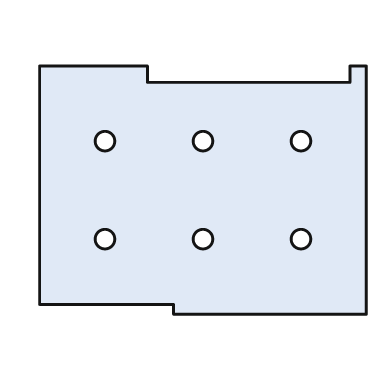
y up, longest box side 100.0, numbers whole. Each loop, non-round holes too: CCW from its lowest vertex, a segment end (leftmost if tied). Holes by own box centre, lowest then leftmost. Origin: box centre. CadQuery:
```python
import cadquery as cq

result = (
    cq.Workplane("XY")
    .moveTo(-9.0, -38.0)
    .lineTo(50.0, -38.0)
    .lineTo(50.0, 38.0)
    .lineTo(45.0, 38.0)
    .lineTo(45.0, 33.0)
    .lineTo(-17.0, 33.0)
    .lineTo(-17.0, 38.0)
    .lineTo(-50.0, 38.0)
    .lineTo(-50.0, -35.0)
    .lineTo(-9.0, -35.0)
    .close()
    .moveTo(-30.0, -15.0)
    .circle(3.0)
    .moveTo(0.0, -15.0)
    .circle(3.0)
    .moveTo(30.0, -15.0)
    .circle(3.0)
    .moveTo(-30.0, 15.0)
    .circle(3.0)
    .moveTo(0.0, 15.0)
    .circle(3.0)
    .moveTo(30.0, 15.0)
    .circle(3.0)
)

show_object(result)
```